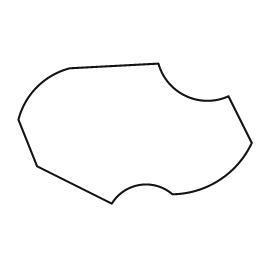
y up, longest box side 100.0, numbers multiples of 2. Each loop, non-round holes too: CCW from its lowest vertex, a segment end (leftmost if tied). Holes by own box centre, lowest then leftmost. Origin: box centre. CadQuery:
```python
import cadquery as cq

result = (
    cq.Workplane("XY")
    .moveTo(-10.0, -30.0)
    .threePointArc((2.0, -22.0), (16.0, -26.0))
    .threePointArc((36.0, -20.0), (50.0, -4.0))
    .lineTo(40.0, 16.0)
    .threePointArc((22.0, 16.0), (10.0, 30.0))
    .lineTo(-28.0, 28.0)
    .threePointArc((-42.0, 20.0), (-50.0, 6.0))
    .lineTo(-42.0, -14.0)
    .close()
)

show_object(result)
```